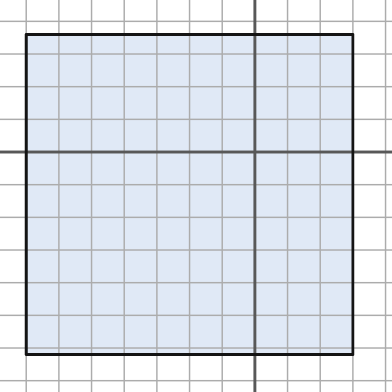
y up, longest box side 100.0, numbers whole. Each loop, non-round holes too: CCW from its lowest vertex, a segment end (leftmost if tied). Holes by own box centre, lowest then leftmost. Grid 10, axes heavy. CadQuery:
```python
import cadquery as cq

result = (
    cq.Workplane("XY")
    .moveTo(-70.0, -62.0)
    .lineTo(30.0, -62.0)
    .lineTo(30.0, 36.0)
    .lineTo(-70.0, 36.0)
    .close()
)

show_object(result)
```